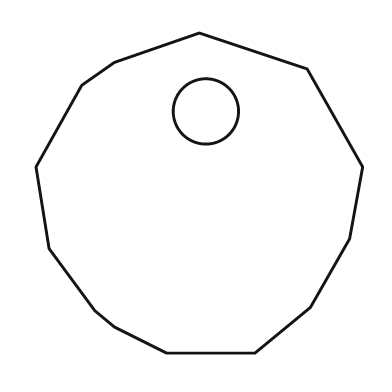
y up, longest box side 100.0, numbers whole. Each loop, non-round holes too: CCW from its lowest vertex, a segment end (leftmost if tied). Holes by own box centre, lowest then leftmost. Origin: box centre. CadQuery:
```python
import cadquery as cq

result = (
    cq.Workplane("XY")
    .moveTo(-10.0, -49.0)
    .lineTo(17.0, -49.0)
    .lineTo(34.0, -35.0)
    .lineTo(46.0, -14.0)
    .lineTo(50.0, 8.0)
    .lineTo(33.0, 38.0)
    .lineTo(0.0, 49.0)
    .lineTo(-26.0, 40.0)
    .lineTo(-36.0, 33.0)
    .lineTo(-50.0, 8.0)
    .lineTo(-46.0, -17.0)
    .lineTo(-32.0, -36.0)
    .lineTo(-26.0, -41.0)
    .close()
    .moveTo(2.0, 25.0)
    .circle(10.0)
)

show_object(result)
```